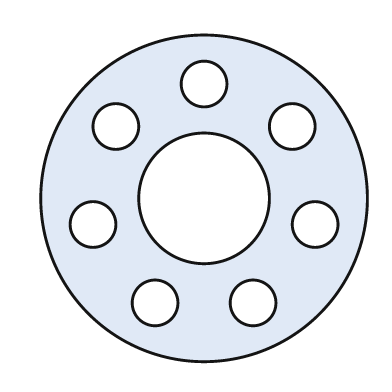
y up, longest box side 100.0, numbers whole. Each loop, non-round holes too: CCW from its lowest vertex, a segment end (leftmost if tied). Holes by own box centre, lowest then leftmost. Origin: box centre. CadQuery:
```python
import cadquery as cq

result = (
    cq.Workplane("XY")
    .moveTo(0.0, 0.0)
    .circle(50.0)
    .moveTo(-15.0, -32.0)
    .circle(7.0)
    .moveTo(15.0, -32.0)
    .circle(7.0)
    .moveTo(-34.0, -8.0)
    .circle(7.0)
    .moveTo(34.0, -8.0)
    .circle(7.0)
    .moveTo(0.0, 0.0)
    .circle(20.0)
    .moveTo(-27.0, 22.0)
    .circle(7.0)
    .moveTo(27.0, 22.0)
    .circle(7.0)
    .moveTo(0.0, 35.0)
    .circle(7.0)
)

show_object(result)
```